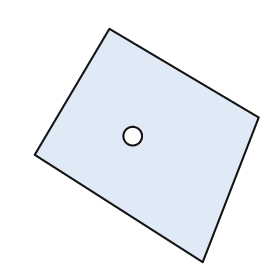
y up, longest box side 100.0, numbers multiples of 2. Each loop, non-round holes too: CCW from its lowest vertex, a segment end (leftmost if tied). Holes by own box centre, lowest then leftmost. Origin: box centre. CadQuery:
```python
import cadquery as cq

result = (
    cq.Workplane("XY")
    .moveTo(24.0, -50.0)
    .lineTo(48.0, 12.0)
    .lineTo(-16.0, 50.0)
    .lineTo(-48.0, -4.0)
    .close()
    .moveTo(-6.0, 4.0)
    .circle(4.0)
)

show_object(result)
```